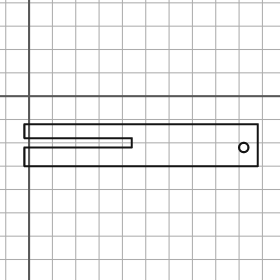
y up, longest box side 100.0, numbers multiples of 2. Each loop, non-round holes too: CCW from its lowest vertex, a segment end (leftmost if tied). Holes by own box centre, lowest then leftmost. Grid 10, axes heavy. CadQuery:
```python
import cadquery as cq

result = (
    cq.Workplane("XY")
    .moveTo(-2.0, -30.0)
    .lineTo(98.0, -30.0)
    .lineTo(98.0, -12.0)
    .lineTo(-2.0, -12.0)
    .lineTo(-2.0, -18.0)
    .lineTo(44.0, -18.0)
    .lineTo(44.0, -22.0)
    .lineTo(-2.0, -22.0)
    .close()
    .moveTo(92.0, -22.0)
    .circle(2.0)
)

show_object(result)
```